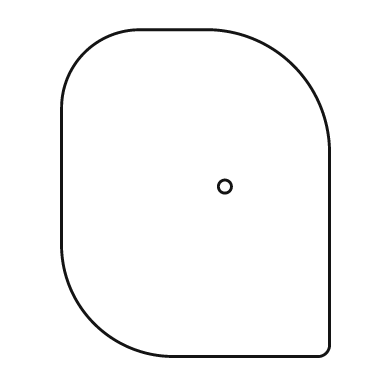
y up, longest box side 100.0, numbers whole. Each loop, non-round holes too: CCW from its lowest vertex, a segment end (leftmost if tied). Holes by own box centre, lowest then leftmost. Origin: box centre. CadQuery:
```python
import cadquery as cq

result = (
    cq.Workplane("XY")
    .moveTo(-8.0, -50.0)
    .lineTo(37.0, -50.0)
    .threePointArc((40.0, -49.0), (41.0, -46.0))
    .lineTo(41.0, 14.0)
    .threePointArc((30.0, 39.0), (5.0, 50.0))
    .lineTo(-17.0, 50.0)
    .threePointArc((-34.0, 43.0), (-41.0, 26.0))
    .lineTo(-41.0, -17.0)
    .threePointArc((-31.0, -40.0), (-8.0, -50.0))
    .close()
    .moveTo(9.0, 2.0)
    .circle(2.0)
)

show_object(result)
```